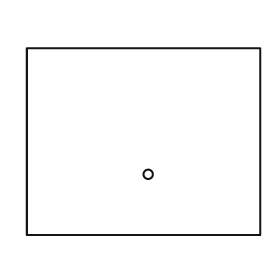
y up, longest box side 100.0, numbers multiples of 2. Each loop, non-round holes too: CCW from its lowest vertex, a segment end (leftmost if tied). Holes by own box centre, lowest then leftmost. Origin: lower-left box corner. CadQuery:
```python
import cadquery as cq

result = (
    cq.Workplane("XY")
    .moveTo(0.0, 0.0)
    .lineTo(100.0, 0.0)
    .lineTo(100.0, 80.0)
    .lineTo(0.0, 80.0)
    .close()
    .moveTo(52.0, 26.0)
    .circle(2.0)
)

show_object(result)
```